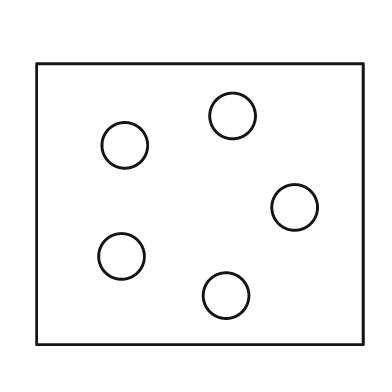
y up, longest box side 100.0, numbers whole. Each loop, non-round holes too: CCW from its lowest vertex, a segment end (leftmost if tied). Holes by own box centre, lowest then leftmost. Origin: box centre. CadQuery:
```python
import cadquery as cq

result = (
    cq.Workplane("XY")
    .moveTo(-50.0, -43.0)
    .lineTo(50.0, -43.0)
    .lineTo(50.0, 43.0)
    .lineTo(-50.0, 43.0)
    .close()
    .moveTo(8.0, -28.0)
    .circle(7.0)
    .moveTo(-24.0, -16.0)
    .circle(7.0)
    .moveTo(29.0, -1.0)
    .circle(7.0)
    .moveTo(-23.0, 18.0)
    .circle(7.0)
    .moveTo(10.0, 27.0)
    .circle(7.0)
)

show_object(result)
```